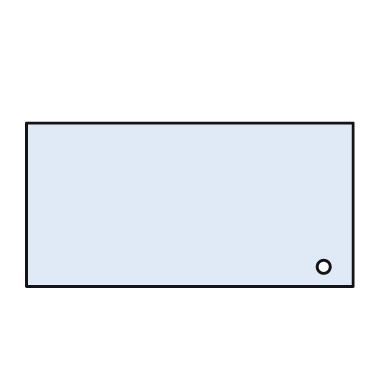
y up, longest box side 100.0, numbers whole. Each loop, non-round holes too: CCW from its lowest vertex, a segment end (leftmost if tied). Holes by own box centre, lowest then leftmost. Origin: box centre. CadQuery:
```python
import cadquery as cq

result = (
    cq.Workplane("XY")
    .moveTo(-50.0, -25.0)
    .lineTo(50.0, -25.0)
    .lineTo(50.0, 25.0)
    .lineTo(-50.0, 25.0)
    .close()
    .moveTo(41.0, -19.0)
    .circle(2.0)
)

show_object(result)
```